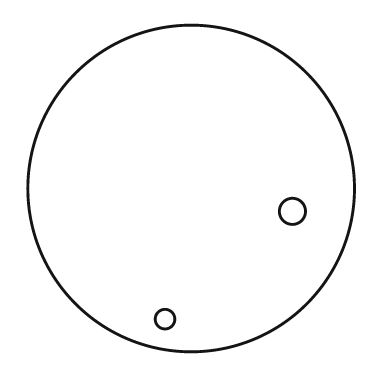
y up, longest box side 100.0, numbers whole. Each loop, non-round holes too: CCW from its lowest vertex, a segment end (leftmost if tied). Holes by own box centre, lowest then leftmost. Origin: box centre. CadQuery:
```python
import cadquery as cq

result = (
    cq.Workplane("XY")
    .moveTo(0.0, 0.0)
    .circle(50.0)
    .moveTo(-8.0, -40.0)
    .circle(3.0)
    .moveTo(31.0, -7.0)
    .circle(4.0)
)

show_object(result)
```